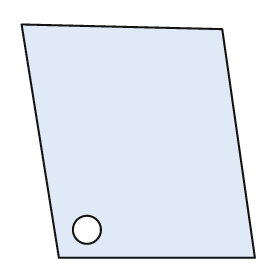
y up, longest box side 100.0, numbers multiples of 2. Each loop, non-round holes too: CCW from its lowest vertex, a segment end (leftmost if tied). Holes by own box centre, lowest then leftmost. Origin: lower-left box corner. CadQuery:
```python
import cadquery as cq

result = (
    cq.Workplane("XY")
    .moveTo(16.0, 0.0)
    .lineTo(100.0, 0.0)
    .lineTo(86.0, 98.0)
    .lineTo(0.0, 100.0)
    .close()
    .moveTo(28.0, 12.0)
    .circle(6.0)
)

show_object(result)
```